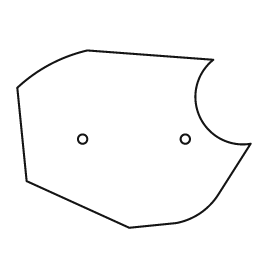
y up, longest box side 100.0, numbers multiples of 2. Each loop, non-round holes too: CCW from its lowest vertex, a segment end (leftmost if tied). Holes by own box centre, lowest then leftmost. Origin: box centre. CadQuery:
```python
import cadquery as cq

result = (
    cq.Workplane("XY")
    .moveTo(-2.0, -38.0)
    .lineTo(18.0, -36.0)
    .threePointArc((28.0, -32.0), (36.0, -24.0))
    .lineTo(50.0, -2.0)
    .threePointArc((28.0, 10.0), (34.0, 34.0))
    .lineTo(-20.0, 38.0)
    .threePointArc((-36.0, 32.0), (-50.0, 22.0))
    .lineTo(-46.0, -18.0)
    .close()
    .moveTo(-22.0, 0.0)
    .circle(2.0)
    .moveTo(22.0, 0.0)
    .circle(2.0)
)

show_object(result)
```